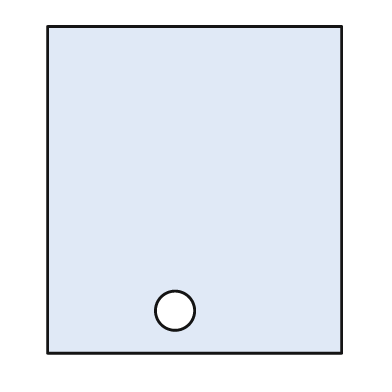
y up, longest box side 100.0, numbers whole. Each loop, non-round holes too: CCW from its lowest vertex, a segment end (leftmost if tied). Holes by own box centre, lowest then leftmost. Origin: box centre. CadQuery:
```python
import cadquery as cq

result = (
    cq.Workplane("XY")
    .moveTo(-45.0, -50.0)
    .lineTo(45.0, -50.0)
    .lineTo(45.0, 50.0)
    .lineTo(-45.0, 50.0)
    .close()
    .moveTo(-6.0, -37.0)
    .circle(6.0)
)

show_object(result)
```